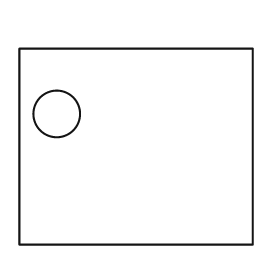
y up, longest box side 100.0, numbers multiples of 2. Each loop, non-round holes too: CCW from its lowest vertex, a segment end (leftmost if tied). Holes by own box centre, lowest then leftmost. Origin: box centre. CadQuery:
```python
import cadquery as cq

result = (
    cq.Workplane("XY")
    .moveTo(-50.0, -42.0)
    .lineTo(50.0, -42.0)
    .lineTo(50.0, 42.0)
    .lineTo(-50.0, 42.0)
    .close()
    .moveTo(-34.0, 14.0)
    .circle(10.0)
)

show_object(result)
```